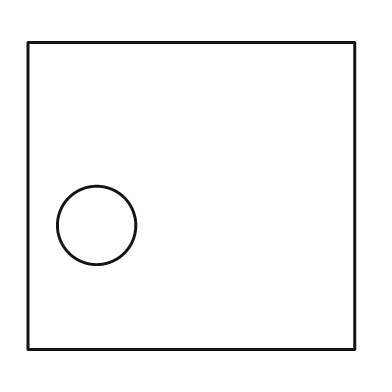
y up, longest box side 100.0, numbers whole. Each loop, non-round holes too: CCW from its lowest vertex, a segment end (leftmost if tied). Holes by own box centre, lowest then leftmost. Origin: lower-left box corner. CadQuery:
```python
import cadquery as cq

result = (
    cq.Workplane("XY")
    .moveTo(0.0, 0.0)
    .lineTo(100.0, 0.0)
    .lineTo(100.0, 94.0)
    .lineTo(0.0, 94.0)
    .close()
    .moveTo(21.0, 38.0)
    .circle(12.0)
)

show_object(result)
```